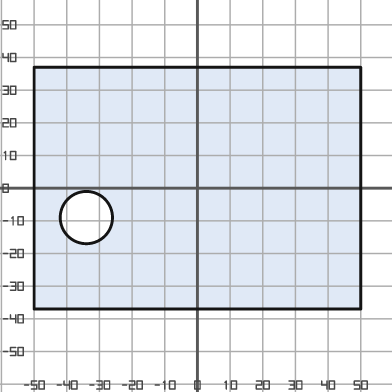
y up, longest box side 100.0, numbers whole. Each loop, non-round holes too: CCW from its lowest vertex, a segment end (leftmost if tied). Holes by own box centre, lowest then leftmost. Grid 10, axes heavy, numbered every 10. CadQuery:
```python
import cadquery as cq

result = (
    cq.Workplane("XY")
    .moveTo(-50.0, -37.0)
    .lineTo(50.0, -37.0)
    .lineTo(50.0, 37.0)
    .lineTo(-50.0, 37.0)
    .close()
    .moveTo(-34.0, -9.0)
    .circle(8.0)
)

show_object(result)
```